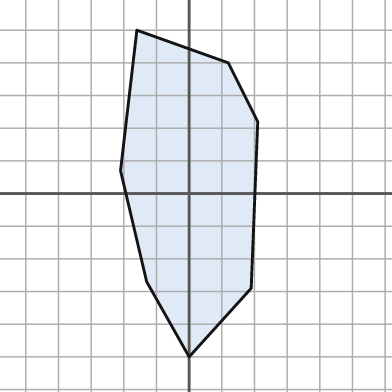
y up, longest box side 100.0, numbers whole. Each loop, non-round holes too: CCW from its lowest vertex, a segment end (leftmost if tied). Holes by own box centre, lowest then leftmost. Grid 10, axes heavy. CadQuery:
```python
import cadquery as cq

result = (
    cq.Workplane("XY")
    .moveTo(0.0, -50.0)
    .lineTo(19.0, -29.0)
    .lineTo(21.0, 22.0)
    .lineTo(12.0, 40.0)
    .lineTo(-16.0, 50.0)
    .lineTo(-21.0, 7.0)
    .lineTo(-13.0, -27.0)
    .close()
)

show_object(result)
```